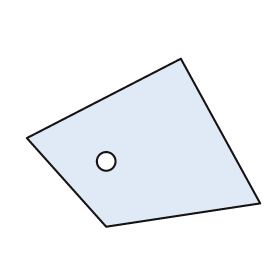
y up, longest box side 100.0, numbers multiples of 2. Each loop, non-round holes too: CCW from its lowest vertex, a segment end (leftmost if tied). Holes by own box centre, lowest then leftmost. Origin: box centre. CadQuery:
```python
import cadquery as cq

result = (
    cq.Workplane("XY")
    .moveTo(-16.0, -36.0)
    .lineTo(50.0, -26.0)
    .lineTo(16.0, 36.0)
    .lineTo(-50.0, 2.0)
    .close()
    .moveTo(-16.0, -8.0)
    .circle(4.0)
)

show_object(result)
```